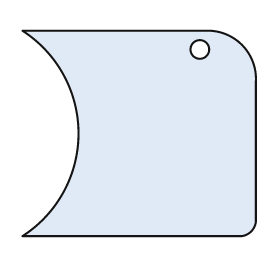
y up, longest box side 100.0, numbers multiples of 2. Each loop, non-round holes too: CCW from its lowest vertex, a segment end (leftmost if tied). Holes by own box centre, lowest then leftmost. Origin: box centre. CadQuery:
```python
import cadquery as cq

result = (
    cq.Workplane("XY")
    .moveTo(-50.0, -44.0)
    .lineTo(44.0, -44.0)
    .threePointArc((48.0, -42.0), (50.0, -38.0))
    .lineTo(50.0, 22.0)
    .threePointArc((44.0, 38.0), (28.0, 44.0))
    .lineTo(-50.0, 44.0)
    .threePointArc((-26.0, 0.0), (-50.0, -44.0))
    .close()
    .moveTo(26.0, 36.0)
    .circle(4.0)
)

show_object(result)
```